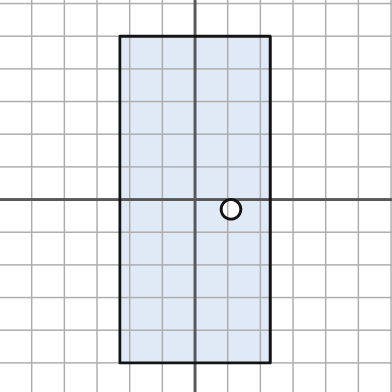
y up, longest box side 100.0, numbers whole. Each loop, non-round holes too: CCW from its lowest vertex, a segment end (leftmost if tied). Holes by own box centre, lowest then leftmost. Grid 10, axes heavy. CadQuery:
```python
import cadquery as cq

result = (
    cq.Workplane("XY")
    .moveTo(-23.0, -50.0)
    .lineTo(23.0, -50.0)
    .lineTo(23.0, 50.0)
    .lineTo(-23.0, 50.0)
    .close()
    .moveTo(11.0, -3.0)
    .circle(3.0)
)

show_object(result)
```